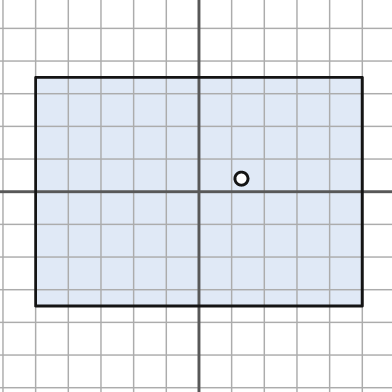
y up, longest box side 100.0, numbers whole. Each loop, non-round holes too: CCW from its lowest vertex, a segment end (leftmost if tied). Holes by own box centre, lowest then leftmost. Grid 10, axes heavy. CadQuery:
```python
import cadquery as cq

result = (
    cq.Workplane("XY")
    .moveTo(-50.0, -35.0)
    .lineTo(50.0, -35.0)
    .lineTo(50.0, 35.0)
    .lineTo(-50.0, 35.0)
    .close()
    .moveTo(13.0, 4.0)
    .circle(2.0)
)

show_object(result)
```